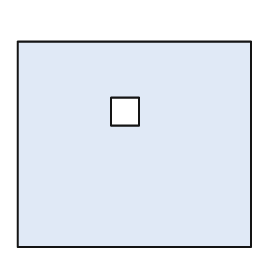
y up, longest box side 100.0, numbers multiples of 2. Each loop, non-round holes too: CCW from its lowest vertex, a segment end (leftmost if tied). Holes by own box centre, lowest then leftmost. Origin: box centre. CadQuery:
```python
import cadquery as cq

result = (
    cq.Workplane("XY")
    .moveTo(-50.0, -44.0)
    .lineTo(50.0, -44.0)
    .lineTo(50.0, 44.0)
    .lineTo(-50.0, 44.0)
    .close()
    .moveTo(-10.0, 8.0)
    .lineTo(2.0, 8.0)
    .lineTo(2.0, 20.0)
    .lineTo(-10.0, 20.0)
    .close()
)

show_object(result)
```